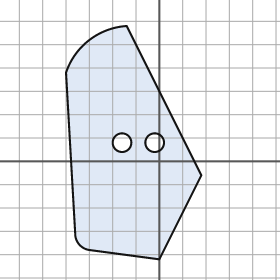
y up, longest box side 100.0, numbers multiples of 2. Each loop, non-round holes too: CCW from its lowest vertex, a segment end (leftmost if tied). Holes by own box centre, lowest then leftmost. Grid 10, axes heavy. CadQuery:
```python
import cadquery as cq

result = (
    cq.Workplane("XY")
    .moveTo(0.0, -42.0)
    .lineTo(18.0, -6.0)
    .lineTo(-14.0, 58.0)
    .threePointArc((-30.0, 52.0), (-40.0, 38.0))
    .lineTo(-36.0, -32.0)
    .threePointArc((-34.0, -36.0), (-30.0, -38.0))
    .close()
    .moveTo(-16.0, 8.0)
    .circle(4.0)
    .moveTo(-2.0, 8.0)
    .circle(4.0)
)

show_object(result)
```